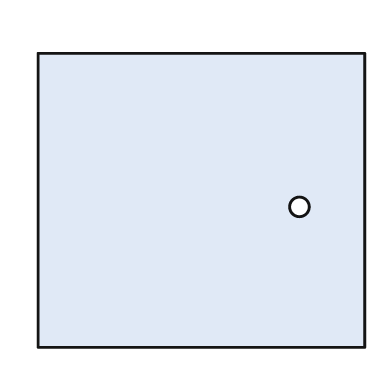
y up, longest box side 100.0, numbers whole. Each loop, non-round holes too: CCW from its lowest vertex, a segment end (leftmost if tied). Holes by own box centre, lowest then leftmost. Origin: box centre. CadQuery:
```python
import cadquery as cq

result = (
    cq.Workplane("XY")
    .moveTo(-50.0, -45.0)
    .lineTo(50.0, -45.0)
    .lineTo(50.0, 45.0)
    .lineTo(-50.0, 45.0)
    .close()
    .moveTo(30.0, -2.0)
    .circle(3.0)
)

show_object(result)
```